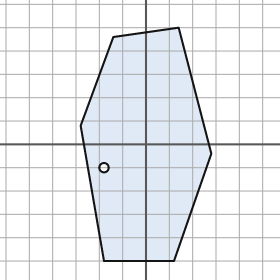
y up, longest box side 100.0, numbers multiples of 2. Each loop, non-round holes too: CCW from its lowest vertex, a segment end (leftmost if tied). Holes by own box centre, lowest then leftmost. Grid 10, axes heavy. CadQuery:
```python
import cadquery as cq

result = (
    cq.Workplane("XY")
    .moveTo(-18.0, -50.0)
    .lineTo(12.0, -50.0)
    .lineTo(28.0, -4.0)
    .lineTo(14.0, 50.0)
    .lineTo(-14.0, 46.0)
    .lineTo(-28.0, 8.0)
    .close()
    .moveTo(-18.0, -10.0)
    .circle(2.0)
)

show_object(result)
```